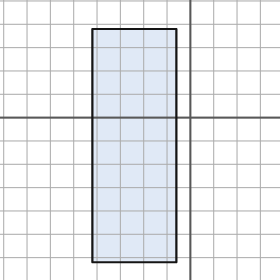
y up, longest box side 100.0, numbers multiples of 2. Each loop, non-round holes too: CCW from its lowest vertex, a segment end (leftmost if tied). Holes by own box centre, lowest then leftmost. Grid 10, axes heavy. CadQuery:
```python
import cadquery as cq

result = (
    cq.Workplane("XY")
    .moveTo(-42.0, -62.0)
    .lineTo(-6.0, -62.0)
    .lineTo(-6.0, 38.0)
    .lineTo(-42.0, 38.0)
    .close()
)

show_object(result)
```